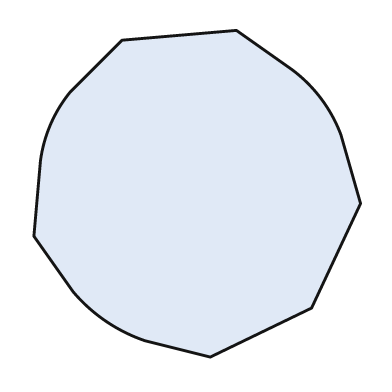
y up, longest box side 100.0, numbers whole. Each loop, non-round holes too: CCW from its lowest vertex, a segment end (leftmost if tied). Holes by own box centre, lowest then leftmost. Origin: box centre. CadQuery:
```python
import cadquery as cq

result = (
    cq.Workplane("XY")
    .moveTo(4.0, -50.0)
    .lineTo(35.0, -35.0)
    .lineTo(50.0, -3.0)
    .lineTo(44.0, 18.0)
    .threePointArc((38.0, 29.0), (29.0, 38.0))
    .lineTo(12.0, 50.0)
    .lineTo(-23.0, 47.0)
    .lineTo(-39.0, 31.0)
    .threePointArc((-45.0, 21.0), (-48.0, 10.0))
    .lineTo(-50.0, -13.0)
    .lineTo(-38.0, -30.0)
    .threePointArc((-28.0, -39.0), (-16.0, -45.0))
    .close()
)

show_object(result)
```